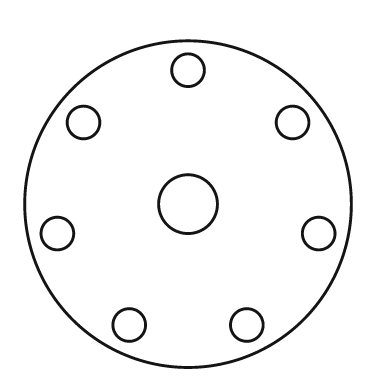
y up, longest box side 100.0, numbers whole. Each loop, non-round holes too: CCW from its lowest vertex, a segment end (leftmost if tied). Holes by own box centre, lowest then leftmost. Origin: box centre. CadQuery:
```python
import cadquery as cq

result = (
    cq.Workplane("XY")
    .moveTo(0.0, 0.0)
    .circle(50.0)
    .moveTo(-18.0, -37.0)
    .circle(5.0)
    .moveTo(18.0, -37.0)
    .circle(5.0)
    .moveTo(-40.0, -9.0)
    .circle(5.0)
    .moveTo(40.0, -9.0)
    .circle(5.0)
    .moveTo(0.0, 0.0)
    .circle(9.0)
    .moveTo(-32.0, 25.0)
    .circle(5.0)
    .moveTo(32.0, 25.0)
    .circle(5.0)
    .moveTo(0.0, 41.0)
    .circle(5.0)
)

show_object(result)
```